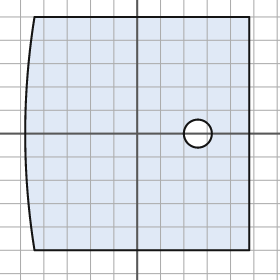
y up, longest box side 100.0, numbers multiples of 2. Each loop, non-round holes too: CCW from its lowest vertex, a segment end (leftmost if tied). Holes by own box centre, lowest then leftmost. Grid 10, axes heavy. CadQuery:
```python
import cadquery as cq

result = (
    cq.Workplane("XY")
    .moveTo(-44.0, -50.0)
    .lineTo(48.0, -50.0)
    .lineTo(48.0, 50.0)
    .lineTo(-44.0, 50.0)
    .threePointArc((-48.0, 0.0), (-44.0, -50.0))
    .close()
    .moveTo(26.0, 0.0)
    .circle(6.0)
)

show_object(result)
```